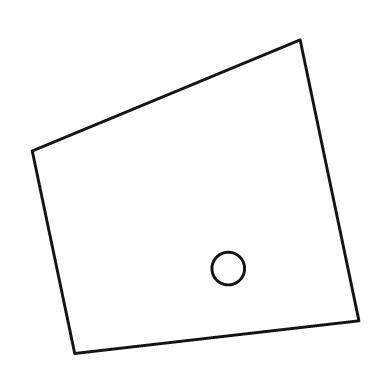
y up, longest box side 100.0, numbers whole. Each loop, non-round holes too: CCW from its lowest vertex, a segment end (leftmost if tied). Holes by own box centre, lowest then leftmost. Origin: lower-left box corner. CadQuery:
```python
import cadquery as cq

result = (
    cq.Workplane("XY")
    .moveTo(13.0, 0.0)
    .lineTo(100.0, 10.0)
    .lineTo(82.0, 96.0)
    .lineTo(0.0, 62.0)
    .close()
    .moveTo(60.0, 26.0)
    .circle(5.0)
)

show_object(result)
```